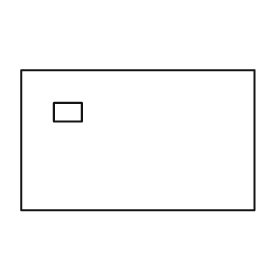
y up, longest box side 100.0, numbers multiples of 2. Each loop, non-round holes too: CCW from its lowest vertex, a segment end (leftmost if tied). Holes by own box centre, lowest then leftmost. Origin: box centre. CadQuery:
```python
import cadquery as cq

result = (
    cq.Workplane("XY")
    .moveTo(-50.0, -30.0)
    .lineTo(50.0, -30.0)
    .lineTo(50.0, 30.0)
    .lineTo(-50.0, 30.0)
    .close()
    .moveTo(-36.0, 8.0)
    .lineTo(-24.0, 8.0)
    .lineTo(-24.0, 16.0)
    .lineTo(-36.0, 16.0)
    .close()
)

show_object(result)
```